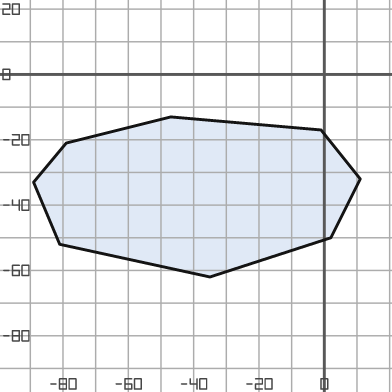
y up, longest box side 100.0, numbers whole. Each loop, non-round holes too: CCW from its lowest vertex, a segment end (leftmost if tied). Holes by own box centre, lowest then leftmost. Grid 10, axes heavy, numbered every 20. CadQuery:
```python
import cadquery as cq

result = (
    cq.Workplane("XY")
    .moveTo(-35.0, -62.0)
    .lineTo(2.0, -50.0)
    .lineTo(11.0, -32.0)
    .lineTo(-1.0, -17.0)
    .lineTo(-47.0, -13.0)
    .lineTo(-79.0, -21.0)
    .lineTo(-89.0, -33.0)
    .lineTo(-81.0, -52.0)
    .close()
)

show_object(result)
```